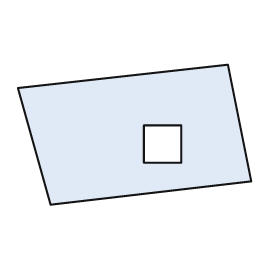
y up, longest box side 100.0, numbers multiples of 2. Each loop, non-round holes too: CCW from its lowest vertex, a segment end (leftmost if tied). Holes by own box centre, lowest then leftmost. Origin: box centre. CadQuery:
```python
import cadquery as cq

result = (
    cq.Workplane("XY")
    .moveTo(-36.0, -30.0)
    .lineTo(50.0, -20.0)
    .lineTo(40.0, 30.0)
    .lineTo(-50.0, 20.0)
    .close()
    .moveTo(4.0, -12.0)
    .lineTo(20.0, -12.0)
    .lineTo(20.0, 4.0)
    .lineTo(4.0, 4.0)
    .close()
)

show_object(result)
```